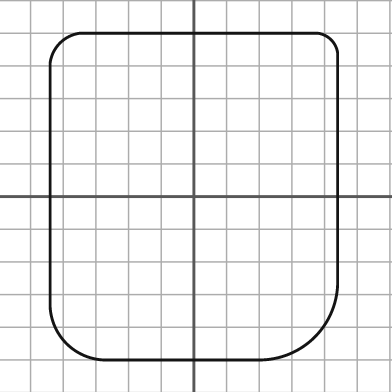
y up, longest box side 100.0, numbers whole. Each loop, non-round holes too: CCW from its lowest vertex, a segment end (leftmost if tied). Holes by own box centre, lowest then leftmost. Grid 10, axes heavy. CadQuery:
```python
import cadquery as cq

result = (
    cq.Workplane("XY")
    .moveTo(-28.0, -50.0)
    .lineTo(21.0, -50.0)
    .threePointArc((37.0, -43.0), (44.0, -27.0))
    .lineTo(44.0, 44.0)
    .threePointArc((42.0, 48.0), (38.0, 50.0))
    .lineTo(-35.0, 50.0)
    .threePointArc((-41.0, 47.0), (-44.0, 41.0))
    .lineTo(-44.0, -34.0)
    .threePointArc((-39.0, -45.0), (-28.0, -50.0))
    .close()
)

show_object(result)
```